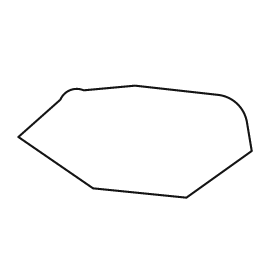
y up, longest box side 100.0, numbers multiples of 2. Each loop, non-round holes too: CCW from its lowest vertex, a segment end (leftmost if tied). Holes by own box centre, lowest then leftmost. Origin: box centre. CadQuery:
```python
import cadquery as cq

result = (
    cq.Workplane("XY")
    .moveTo(22.0, -24.0)
    .lineTo(50.0, -4.0)
    .lineTo(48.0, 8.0)
    .threePointArc((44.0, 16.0), (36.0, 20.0))
    .lineTo(0.0, 24.0)
    .lineTo(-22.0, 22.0)
    .threePointArc((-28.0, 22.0), (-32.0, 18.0))
    .lineTo(-50.0, 2.0)
    .lineTo(-18.0, -20.0)
    .close()
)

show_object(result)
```